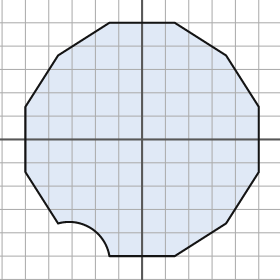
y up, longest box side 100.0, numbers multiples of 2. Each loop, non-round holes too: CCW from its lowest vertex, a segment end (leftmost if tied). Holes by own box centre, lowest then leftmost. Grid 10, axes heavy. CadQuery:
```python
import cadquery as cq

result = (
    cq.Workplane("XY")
    .moveTo(-14.0, -50.0)
    .lineTo(14.0, -50.0)
    .lineTo(36.0, -36.0)
    .lineTo(50.0, -14.0)
    .lineTo(50.0, 14.0)
    .lineTo(36.0, 36.0)
    .lineTo(14.0, 50.0)
    .lineTo(-14.0, 50.0)
    .lineTo(-36.0, 36.0)
    .lineTo(-50.0, 14.0)
    .lineTo(-50.0, -14.0)
    .lineTo(-36.0, -36.0)
    .threePointArc((-22.0, -38.0), (-14.0, -50.0))
    .close()
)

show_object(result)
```